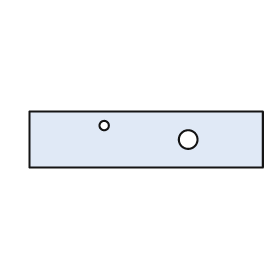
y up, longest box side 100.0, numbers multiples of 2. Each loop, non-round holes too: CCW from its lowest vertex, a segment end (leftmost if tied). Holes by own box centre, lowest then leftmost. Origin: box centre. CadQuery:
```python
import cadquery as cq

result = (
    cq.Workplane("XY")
    .moveTo(-50.0, -12.0)
    .lineTo(50.0, -12.0)
    .lineTo(50.0, 12.0)
    .lineTo(-50.0, 12.0)
    .close()
    .moveTo(18.0, 0.0)
    .circle(4.0)
    .moveTo(-18.0, 6.0)
    .circle(2.0)
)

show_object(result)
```